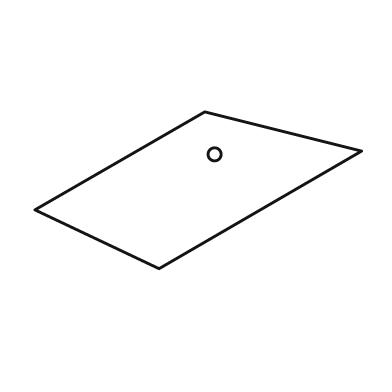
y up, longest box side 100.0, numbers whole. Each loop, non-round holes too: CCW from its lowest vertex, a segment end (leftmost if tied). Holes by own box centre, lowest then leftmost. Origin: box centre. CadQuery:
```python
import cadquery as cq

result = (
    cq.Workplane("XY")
    .moveTo(-12.0, -24.0)
    .lineTo(50.0, 12.0)
    .lineTo(2.0, 24.0)
    .lineTo(-50.0, -6.0)
    .close()
    .moveTo(5.0, 11.0)
    .circle(2.0)
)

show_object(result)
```